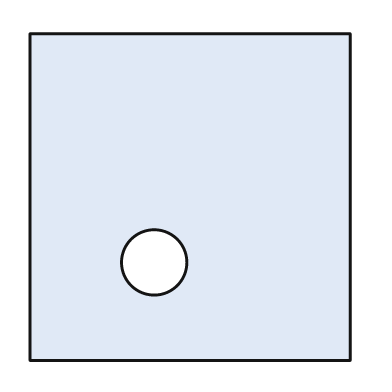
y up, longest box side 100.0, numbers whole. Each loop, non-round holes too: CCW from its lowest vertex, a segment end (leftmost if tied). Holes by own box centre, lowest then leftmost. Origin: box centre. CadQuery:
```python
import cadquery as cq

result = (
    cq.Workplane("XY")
    .moveTo(-49.0, -50.0)
    .lineTo(49.0, -50.0)
    .lineTo(49.0, 50.0)
    .lineTo(-49.0, 50.0)
    .close()
    .moveTo(-11.0, -20.0)
    .circle(10.0)
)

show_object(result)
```